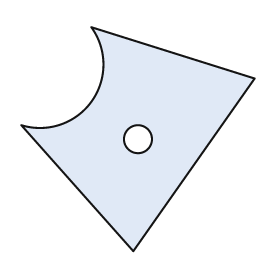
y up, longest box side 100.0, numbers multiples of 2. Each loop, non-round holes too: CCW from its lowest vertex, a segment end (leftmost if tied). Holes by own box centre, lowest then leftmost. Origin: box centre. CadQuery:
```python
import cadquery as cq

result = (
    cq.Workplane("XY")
    .moveTo(-2.0, -48.0)
    .lineTo(50.0, 26.0)
    .lineTo(-20.0, 48.0)
    .threePointArc((-20.0, 16.0), (-50.0, 6.0))
    .close()
    .moveTo(0.0, 0.0)
    .circle(6.0)
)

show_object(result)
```